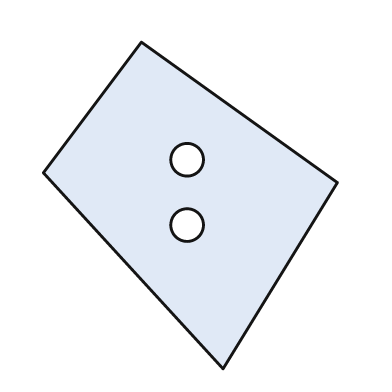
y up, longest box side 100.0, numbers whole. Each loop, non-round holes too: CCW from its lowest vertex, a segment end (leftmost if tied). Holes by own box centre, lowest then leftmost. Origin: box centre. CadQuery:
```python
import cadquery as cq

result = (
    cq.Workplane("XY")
    .moveTo(10.0, -50.0)
    .lineTo(45.0, 7.0)
    .lineTo(-15.0, 50.0)
    .lineTo(-45.0, 10.0)
    .close()
    .moveTo(-1.0, -6.0)
    .circle(5.0)
    .moveTo(-1.0, 14.0)
    .circle(5.0)
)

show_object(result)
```